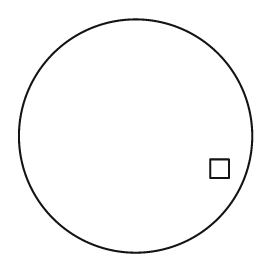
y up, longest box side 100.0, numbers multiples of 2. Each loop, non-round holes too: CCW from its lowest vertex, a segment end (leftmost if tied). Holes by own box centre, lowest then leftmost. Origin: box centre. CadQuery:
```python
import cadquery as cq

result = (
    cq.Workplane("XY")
    .moveTo(0.0, 0.0)
    .circle(50.0)
    .moveTo(32.0, -18.0)
    .lineTo(40.0, -18.0)
    .lineTo(40.0, -10.0)
    .lineTo(32.0, -10.0)
    .close()
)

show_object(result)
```